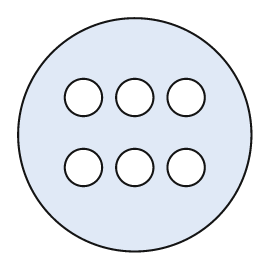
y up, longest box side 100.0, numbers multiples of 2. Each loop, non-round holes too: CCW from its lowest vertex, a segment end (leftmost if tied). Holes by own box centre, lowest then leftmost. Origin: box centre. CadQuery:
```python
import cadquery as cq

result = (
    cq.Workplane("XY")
    .moveTo(0.0, 0.0)
    .circle(50.0)
    .moveTo(-22.0, -14.0)
    .circle(8.0)
    .moveTo(0.0, -14.0)
    .circle(8.0)
    .moveTo(22.0, -14.0)
    .circle(8.0)
    .moveTo(-22.0, 16.0)
    .circle(8.0)
    .moveTo(0.0, 16.0)
    .circle(8.0)
    .moveTo(22.0, 16.0)
    .circle(8.0)
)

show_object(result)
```